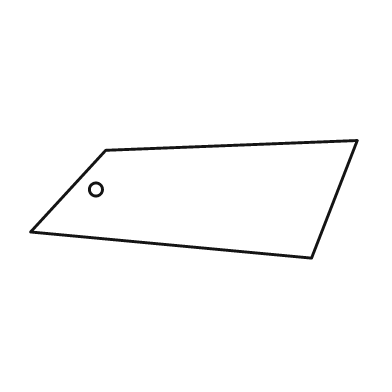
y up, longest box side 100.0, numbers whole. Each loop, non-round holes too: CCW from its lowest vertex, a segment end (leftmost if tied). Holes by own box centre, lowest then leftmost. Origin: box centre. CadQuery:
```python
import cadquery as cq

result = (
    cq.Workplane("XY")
    .moveTo(36.0, -18.0)
    .lineTo(50.0, 18.0)
    .lineTo(-27.0, 15.0)
    .lineTo(-50.0, -10.0)
    .close()
    .moveTo(-30.0, 3.0)
    .circle(2.0)
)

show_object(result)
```